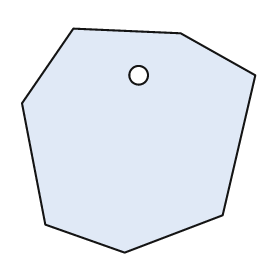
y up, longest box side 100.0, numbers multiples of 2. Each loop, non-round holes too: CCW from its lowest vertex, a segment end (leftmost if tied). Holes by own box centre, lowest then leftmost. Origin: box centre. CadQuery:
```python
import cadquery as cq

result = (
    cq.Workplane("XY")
    .moveTo(-6.0, -48.0)
    .lineTo(36.0, -32.0)
    .lineTo(50.0, 28.0)
    .lineTo(18.0, 46.0)
    .lineTo(-28.0, 48.0)
    .lineTo(-50.0, 16.0)
    .lineTo(-40.0, -36.0)
    .close()
    .moveTo(0.0, 28.0)
    .circle(4.0)
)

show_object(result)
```